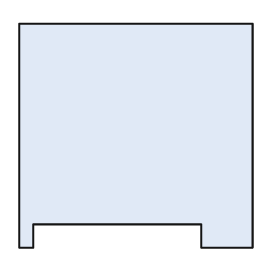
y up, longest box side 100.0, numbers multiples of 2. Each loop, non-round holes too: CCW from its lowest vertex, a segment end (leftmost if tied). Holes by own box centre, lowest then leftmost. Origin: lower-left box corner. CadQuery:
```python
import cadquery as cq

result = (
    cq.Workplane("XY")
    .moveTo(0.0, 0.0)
    .lineTo(6.0, 0.0)
    .lineTo(6.0, 10.0)
    .lineTo(78.0, 10.0)
    .lineTo(78.0, 0.0)
    .lineTo(100.0, 0.0)
    .lineTo(100.0, 96.0)
    .lineTo(0.0, 96.0)
    .close()
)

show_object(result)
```